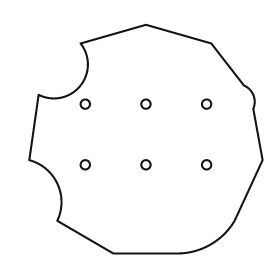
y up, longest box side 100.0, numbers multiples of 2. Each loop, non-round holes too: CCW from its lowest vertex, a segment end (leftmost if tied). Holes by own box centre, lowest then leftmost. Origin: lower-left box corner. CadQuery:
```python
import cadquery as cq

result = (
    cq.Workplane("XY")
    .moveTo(36.0, 0.0)
    .lineTo(64.0, 0.0)
    .threePointArc((78.0, 4.0), (88.0, 14.0))
    .lineTo(100.0, 40.0)
    .lineTo(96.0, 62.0)
    .threePointArc((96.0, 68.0), (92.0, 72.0))
    .lineTo(78.0, 90.0)
    .lineTo(50.0, 98.0)
    .lineTo(22.0, 90.0)
    .threePointArc((22.0, 72.0), (4.0, 68.0))
    .lineTo(0.0, 40.0)
    .threePointArc((12.0, 30.0), (12.0, 14.0))
    .close()
    .moveTo(24.0, 38.0)
    .circle(2.0)
    .moveTo(50.0, 38.0)
    .circle(2.0)
    .moveTo(76.0, 38.0)
    .circle(2.0)
    .moveTo(24.0, 64.0)
    .circle(2.0)
    .moveTo(50.0, 64.0)
    .circle(2.0)
    .moveTo(76.0, 64.0)
    .circle(2.0)
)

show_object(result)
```